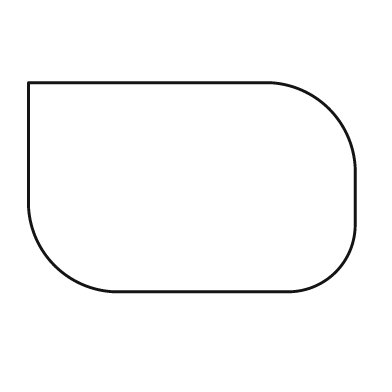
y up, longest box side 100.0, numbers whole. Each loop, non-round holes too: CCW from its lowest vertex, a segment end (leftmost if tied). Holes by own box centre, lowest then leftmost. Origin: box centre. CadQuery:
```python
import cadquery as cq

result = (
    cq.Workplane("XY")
    .moveTo(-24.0, -32.0)
    .lineTo(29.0, -32.0)
    .threePointArc((44.0, -26.0), (50.0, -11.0))
    .lineTo(50.0, 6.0)
    .threePointArc((42.0, 24.0), (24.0, 32.0))
    .lineTo(-50.0, 32.0)
    .lineTo(-50.0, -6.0)
    .threePointArc((-42.0, -24.0), (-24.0, -32.0))
    .close()
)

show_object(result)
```